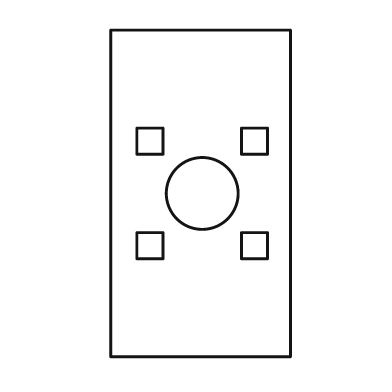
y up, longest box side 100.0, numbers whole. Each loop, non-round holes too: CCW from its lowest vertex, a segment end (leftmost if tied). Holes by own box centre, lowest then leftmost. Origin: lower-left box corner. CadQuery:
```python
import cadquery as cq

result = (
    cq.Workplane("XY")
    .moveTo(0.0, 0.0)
    .lineTo(55.0, 0.0)
    .lineTo(55.0, 100.0)
    .lineTo(0.0, 100.0)
    .close()
    .moveTo(8.0, 30.0)
    .lineTo(16.0, 30.0)
    .lineTo(16.0, 38.0)
    .lineTo(8.0, 38.0)
    .close()
    .moveTo(40.0, 30.0)
    .lineTo(48.0, 30.0)
    .lineTo(48.0, 38.0)
    .lineTo(40.0, 38.0)
    .close()
    .moveTo(28.0, 50.0)
    .circle(11.0)
    .moveTo(8.0, 62.0)
    .lineTo(16.0, 62.0)
    .lineTo(16.0, 70.0)
    .lineTo(8.0, 70.0)
    .close()
    .moveTo(40.0, 62.0)
    .lineTo(48.0, 62.0)
    .lineTo(48.0, 70.0)
    .lineTo(40.0, 70.0)
    .close()
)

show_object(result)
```